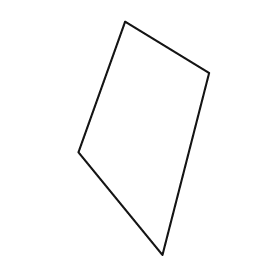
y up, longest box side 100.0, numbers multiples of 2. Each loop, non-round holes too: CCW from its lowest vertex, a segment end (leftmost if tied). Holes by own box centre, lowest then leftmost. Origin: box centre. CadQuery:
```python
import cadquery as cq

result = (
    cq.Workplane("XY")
    .moveTo(8.0, -50.0)
    .lineTo(28.0, 28.0)
    .lineTo(-8.0, 50.0)
    .lineTo(-28.0, -6.0)
    .close()
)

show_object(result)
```